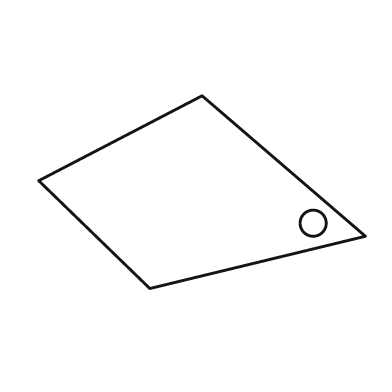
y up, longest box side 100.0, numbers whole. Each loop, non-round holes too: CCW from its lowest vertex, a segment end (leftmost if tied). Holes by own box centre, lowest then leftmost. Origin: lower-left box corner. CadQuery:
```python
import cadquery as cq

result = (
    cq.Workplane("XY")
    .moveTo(34.0, 0.0)
    .lineTo(100.0, 16.0)
    .lineTo(50.0, 59.0)
    .lineTo(0.0, 33.0)
    .close()
    .moveTo(84.0, 20.0)
    .circle(4.0)
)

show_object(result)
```